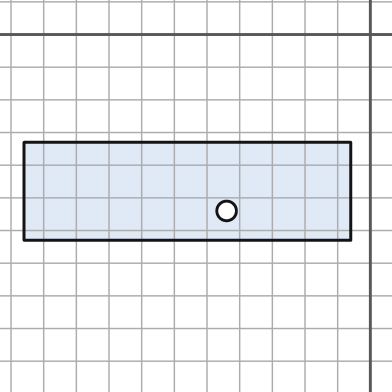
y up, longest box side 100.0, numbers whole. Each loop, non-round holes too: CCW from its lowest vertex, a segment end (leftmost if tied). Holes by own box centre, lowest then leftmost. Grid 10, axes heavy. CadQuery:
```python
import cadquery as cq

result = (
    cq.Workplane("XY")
    .moveTo(-106.0, -63.0)
    .lineTo(-6.0, -63.0)
    .lineTo(-6.0, -33.0)
    .lineTo(-106.0, -33.0)
    .close()
    .moveTo(-44.0, -54.0)
    .circle(3.0)
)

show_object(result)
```